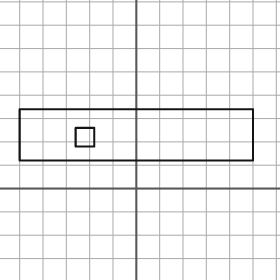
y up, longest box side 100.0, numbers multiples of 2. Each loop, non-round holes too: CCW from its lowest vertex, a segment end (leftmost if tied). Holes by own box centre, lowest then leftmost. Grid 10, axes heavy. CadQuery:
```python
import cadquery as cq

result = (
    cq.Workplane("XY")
    .moveTo(-50.0, 12.0)
    .lineTo(50.0, 12.0)
    .lineTo(50.0, 34.0)
    .lineTo(-50.0, 34.0)
    .close()
    .moveTo(-26.0, 18.0)
    .lineTo(-18.0, 18.0)
    .lineTo(-18.0, 26.0)
    .lineTo(-26.0, 26.0)
    .close()
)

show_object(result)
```